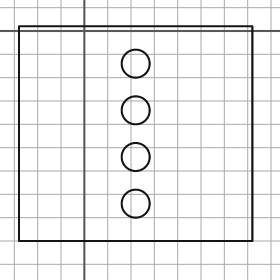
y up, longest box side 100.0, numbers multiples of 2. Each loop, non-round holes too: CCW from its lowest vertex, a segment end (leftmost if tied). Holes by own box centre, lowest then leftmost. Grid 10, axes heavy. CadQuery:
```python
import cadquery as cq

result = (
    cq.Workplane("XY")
    .moveTo(-28.0, -90.0)
    .lineTo(72.0, -90.0)
    .lineTo(72.0, 2.0)
    .lineTo(-28.0, 2.0)
    .close()
    .moveTo(22.0, -74.0)
    .circle(6.0)
    .moveTo(22.0, -54.0)
    .circle(6.0)
    .moveTo(22.0, -34.0)
    .circle(6.0)
    .moveTo(22.0, -14.0)
    .circle(6.0)
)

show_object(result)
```